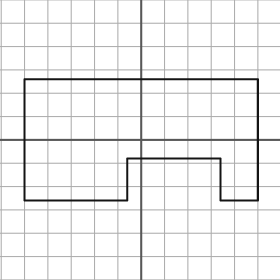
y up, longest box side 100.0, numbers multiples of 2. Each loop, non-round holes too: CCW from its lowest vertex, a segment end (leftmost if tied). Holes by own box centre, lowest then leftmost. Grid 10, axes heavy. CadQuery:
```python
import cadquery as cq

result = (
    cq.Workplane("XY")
    .moveTo(-50.0, -26.0)
    .lineTo(-6.0, -26.0)
    .lineTo(-6.0, -8.0)
    .lineTo(34.0, -8.0)
    .lineTo(34.0, -26.0)
    .lineTo(50.0, -26.0)
    .lineTo(50.0, 26.0)
    .lineTo(-50.0, 26.0)
    .close()
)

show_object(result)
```